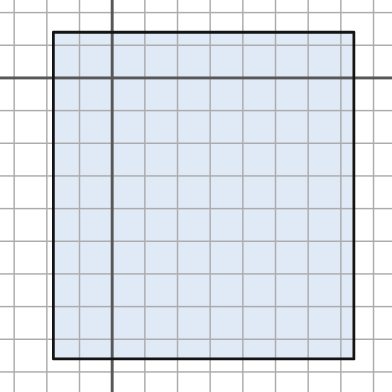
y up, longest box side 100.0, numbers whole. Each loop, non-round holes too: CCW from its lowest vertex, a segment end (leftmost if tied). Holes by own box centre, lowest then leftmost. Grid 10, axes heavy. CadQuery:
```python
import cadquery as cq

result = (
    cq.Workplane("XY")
    .moveTo(-18.0, -86.0)
    .lineTo(74.0, -86.0)
    .lineTo(74.0, 14.0)
    .lineTo(-18.0, 14.0)
    .close()
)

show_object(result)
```